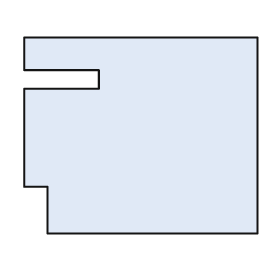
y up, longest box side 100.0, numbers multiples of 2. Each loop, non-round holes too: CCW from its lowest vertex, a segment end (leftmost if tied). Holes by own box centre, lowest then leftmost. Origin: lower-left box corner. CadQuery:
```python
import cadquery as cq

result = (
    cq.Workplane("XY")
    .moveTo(10.0, 0.0)
    .lineTo(100.0, 0.0)
    .lineTo(100.0, 84.0)
    .lineTo(0.0, 84.0)
    .lineTo(0.0, 70.0)
    .lineTo(32.0, 70.0)
    .lineTo(32.0, 62.0)
    .lineTo(0.0, 62.0)
    .lineTo(0.0, 20.0)
    .lineTo(10.0, 20.0)
    .close()
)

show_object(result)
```